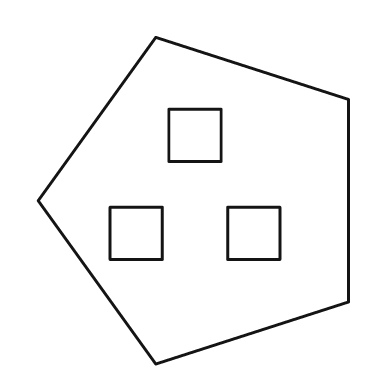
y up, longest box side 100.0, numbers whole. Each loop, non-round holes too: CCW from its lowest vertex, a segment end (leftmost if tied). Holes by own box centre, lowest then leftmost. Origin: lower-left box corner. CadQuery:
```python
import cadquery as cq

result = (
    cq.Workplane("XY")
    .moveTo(36.0, 0.0)
    .lineTo(95.0, 19.0)
    .lineTo(95.0, 81.0)
    .lineTo(36.0, 100.0)
    .lineTo(0.0, 50.0)
    .close()
    .moveTo(22.0, 32.0)
    .lineTo(38.0, 32.0)
    .lineTo(38.0, 48.0)
    .lineTo(22.0, 48.0)
    .close()
    .moveTo(58.0, 32.0)
    .lineTo(74.0, 32.0)
    .lineTo(74.0, 48.0)
    .lineTo(58.0, 48.0)
    .close()
    .moveTo(40.0, 62.0)
    .lineTo(56.0, 62.0)
    .lineTo(56.0, 78.0)
    .lineTo(40.0, 78.0)
    .close()
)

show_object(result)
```